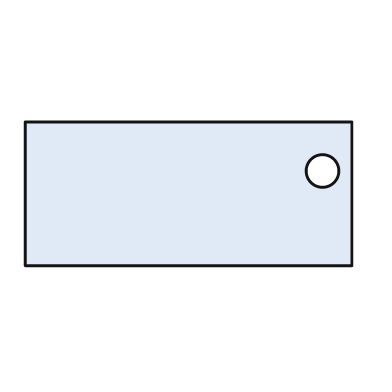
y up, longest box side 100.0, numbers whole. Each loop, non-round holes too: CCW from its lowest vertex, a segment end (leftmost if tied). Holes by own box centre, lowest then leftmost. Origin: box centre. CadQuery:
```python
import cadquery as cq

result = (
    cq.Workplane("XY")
    .moveTo(-50.0, -22.0)
    .lineTo(50.0, -22.0)
    .lineTo(50.0, 22.0)
    .lineTo(-50.0, 22.0)
    .close()
    .moveTo(41.0, 7.0)
    .circle(5.0)
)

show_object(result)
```